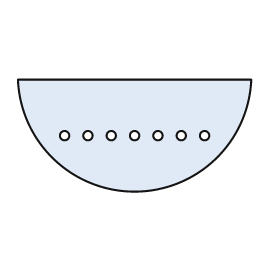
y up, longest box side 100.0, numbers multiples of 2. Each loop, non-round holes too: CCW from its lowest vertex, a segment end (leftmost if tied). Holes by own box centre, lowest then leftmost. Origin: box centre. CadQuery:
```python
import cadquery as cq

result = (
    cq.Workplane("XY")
    .moveTo(-50.0, 24.0)
    .threePointArc((0.0, -24.0), (50.0, 24.0))
    .close()
    .moveTo(-30.0, 0.0)
    .circle(2.0)
    .moveTo(-20.0, 0.0)
    .circle(2.0)
    .moveTo(-10.0, 0.0)
    .circle(2.0)
    .moveTo(0.0, 0.0)
    .circle(2.0)
    .moveTo(10.0, 0.0)
    .circle(2.0)
    .moveTo(20.0, 0.0)
    .circle(2.0)
    .moveTo(30.0, 0.0)
    .circle(2.0)
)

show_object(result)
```